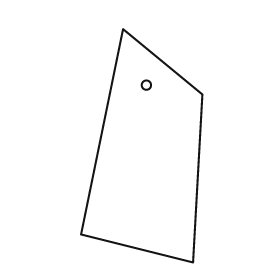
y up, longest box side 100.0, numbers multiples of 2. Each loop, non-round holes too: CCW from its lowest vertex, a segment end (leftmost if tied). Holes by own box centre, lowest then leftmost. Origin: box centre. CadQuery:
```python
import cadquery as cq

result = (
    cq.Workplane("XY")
    .moveTo(22.0, -50.0)
    .lineTo(26.0, 22.0)
    .lineTo(-8.0, 50.0)
    .lineTo(-26.0, -38.0)
    .close()
    .moveTo(2.0, 26.0)
    .circle(2.0)
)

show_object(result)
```